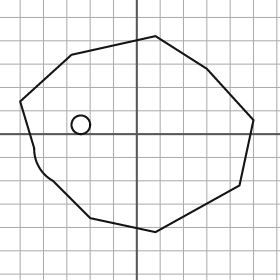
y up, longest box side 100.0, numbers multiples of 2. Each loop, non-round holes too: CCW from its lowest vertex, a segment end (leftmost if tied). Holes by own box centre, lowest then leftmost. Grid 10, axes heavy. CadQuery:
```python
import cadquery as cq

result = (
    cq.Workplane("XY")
    .moveTo(8.0, -42.0)
    .lineTo(44.0, -22.0)
    .lineTo(50.0, 6.0)
    .lineTo(30.0, 28.0)
    .lineTo(8.0, 42.0)
    .lineTo(-28.0, 34.0)
    .lineTo(-50.0, 14.0)
    .lineTo(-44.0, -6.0)
    .threePointArc((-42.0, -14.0), (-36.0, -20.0))
    .lineTo(-20.0, -36.0)
    .close()
    .moveTo(-24.0, 4.0)
    .circle(4.0)
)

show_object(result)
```